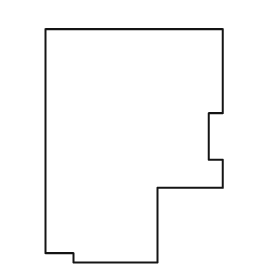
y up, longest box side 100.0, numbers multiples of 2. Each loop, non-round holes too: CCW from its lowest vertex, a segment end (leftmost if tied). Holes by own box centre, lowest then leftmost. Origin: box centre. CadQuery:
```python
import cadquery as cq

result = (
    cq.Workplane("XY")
    .moveTo(-26.0, -50.0)
    .lineTo(10.0, -50.0)
    .lineTo(10.0, -18.0)
    .lineTo(38.0, -18.0)
    .lineTo(38.0, -6.0)
    .lineTo(32.0, -6.0)
    .lineTo(32.0, 14.0)
    .lineTo(38.0, 14.0)
    .lineTo(38.0, 50.0)
    .lineTo(-38.0, 50.0)
    .lineTo(-38.0, -46.0)
    .lineTo(-26.0, -46.0)
    .close()
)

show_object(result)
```